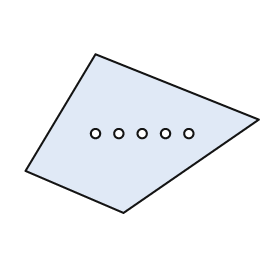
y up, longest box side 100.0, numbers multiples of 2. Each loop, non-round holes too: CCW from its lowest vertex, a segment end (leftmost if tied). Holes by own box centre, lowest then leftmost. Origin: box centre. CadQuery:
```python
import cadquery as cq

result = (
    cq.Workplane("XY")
    .moveTo(-8.0, -34.0)
    .lineTo(50.0, 6.0)
    .lineTo(-20.0, 34.0)
    .lineTo(-50.0, -16.0)
    .close()
    .moveTo(-20.0, 0.0)
    .circle(2.0)
    .moveTo(-10.0, 0.0)
    .circle(2.0)
    .moveTo(0.0, 0.0)
    .circle(2.0)
    .moveTo(10.0, 0.0)
    .circle(2.0)
    .moveTo(20.0, 0.0)
    .circle(2.0)
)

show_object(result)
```